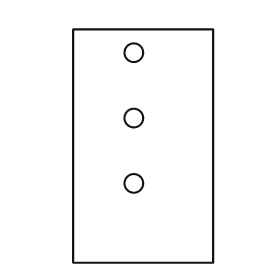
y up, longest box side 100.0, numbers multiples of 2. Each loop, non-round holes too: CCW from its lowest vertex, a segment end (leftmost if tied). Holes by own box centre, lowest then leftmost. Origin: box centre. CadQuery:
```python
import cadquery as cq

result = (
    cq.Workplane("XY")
    .moveTo(-30.0, -50.0)
    .lineTo(30.0, -50.0)
    .lineTo(30.0, 50.0)
    .lineTo(-30.0, 50.0)
    .close()
    .moveTo(-4.0, -16.0)
    .circle(4.0)
    .moveTo(-4.0, 12.0)
    .circle(4.0)
    .moveTo(-4.0, 40.0)
    .circle(4.0)
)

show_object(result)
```